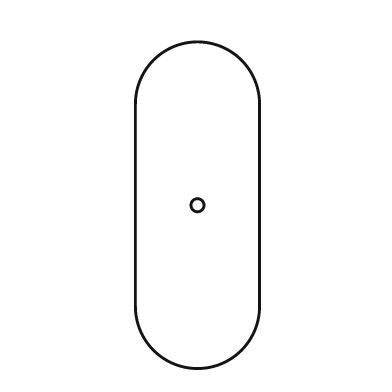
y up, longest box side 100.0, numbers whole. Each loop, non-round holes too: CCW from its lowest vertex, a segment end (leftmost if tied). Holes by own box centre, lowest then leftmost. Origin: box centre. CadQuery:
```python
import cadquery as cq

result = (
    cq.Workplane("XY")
    .moveTo(-19.0, -31.0)
    .threePointArc((0.0, -50.0), (19.0, -31.0))
    .lineTo(19.0, 31.0)
    .threePointArc((0.0, 50.0), (-19.0, 31.0))
    .close()
    .moveTo(0.0, 0.0)
    .circle(2.0)
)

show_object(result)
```